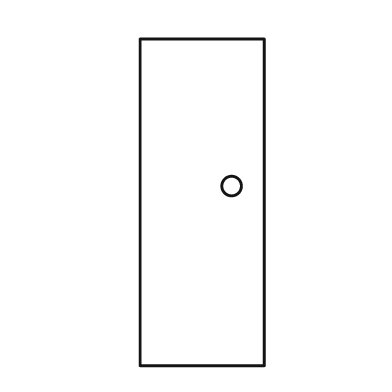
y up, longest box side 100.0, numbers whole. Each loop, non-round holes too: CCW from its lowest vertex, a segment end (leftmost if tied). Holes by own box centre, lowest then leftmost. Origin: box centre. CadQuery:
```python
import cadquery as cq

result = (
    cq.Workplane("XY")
    .moveTo(-19.0, -50.0)
    .lineTo(19.0, -50.0)
    .lineTo(19.0, 50.0)
    .lineTo(-19.0, 50.0)
    .close()
    .moveTo(9.0, 5.0)
    .circle(3.0)
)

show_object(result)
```